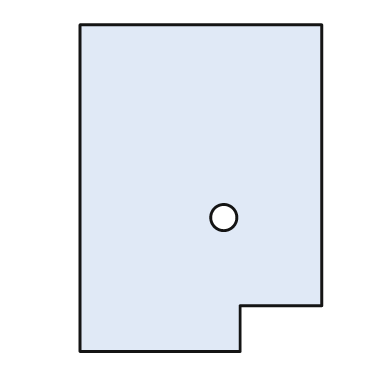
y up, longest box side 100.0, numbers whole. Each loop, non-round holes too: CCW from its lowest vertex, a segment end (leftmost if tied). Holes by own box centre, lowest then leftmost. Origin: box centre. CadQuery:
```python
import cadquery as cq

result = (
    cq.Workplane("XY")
    .moveTo(-37.0, -50.0)
    .lineTo(12.0, -50.0)
    .lineTo(12.0, -36.0)
    .lineTo(37.0, -36.0)
    .lineTo(37.0, 50.0)
    .lineTo(-37.0, 50.0)
    .close()
    .moveTo(7.0, -9.0)
    .circle(4.0)
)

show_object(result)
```